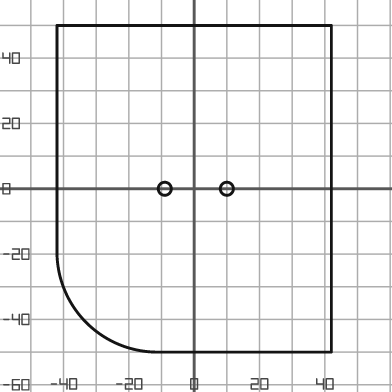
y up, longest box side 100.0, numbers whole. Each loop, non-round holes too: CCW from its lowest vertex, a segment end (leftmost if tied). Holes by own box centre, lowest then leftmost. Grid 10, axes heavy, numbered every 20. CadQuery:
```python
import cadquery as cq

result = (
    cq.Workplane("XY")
    .moveTo(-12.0, -50.0)
    .lineTo(42.0, -50.0)
    .lineTo(42.0, 50.0)
    .lineTo(-42.0, 50.0)
    .lineTo(-42.0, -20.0)
    .threePointArc((-33.0, -41.0), (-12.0, -50.0))
    .close()
    .moveTo(-9.0, 0.0)
    .circle(2.0)
    .moveTo(10.0, 0.0)
    .circle(2.0)
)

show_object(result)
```